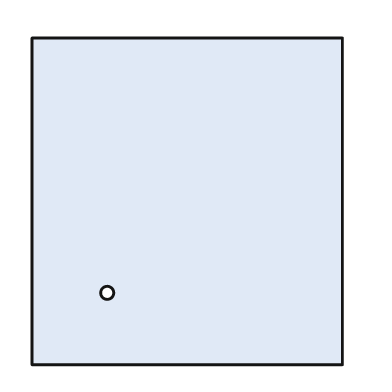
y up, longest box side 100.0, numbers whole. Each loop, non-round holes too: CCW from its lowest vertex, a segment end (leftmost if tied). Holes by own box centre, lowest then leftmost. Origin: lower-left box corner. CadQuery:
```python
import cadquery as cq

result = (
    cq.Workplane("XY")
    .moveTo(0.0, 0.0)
    .lineTo(95.0, 0.0)
    .lineTo(95.0, 100.0)
    .lineTo(0.0, 100.0)
    .close()
    .moveTo(23.0, 22.0)
    .circle(2.0)
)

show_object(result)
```